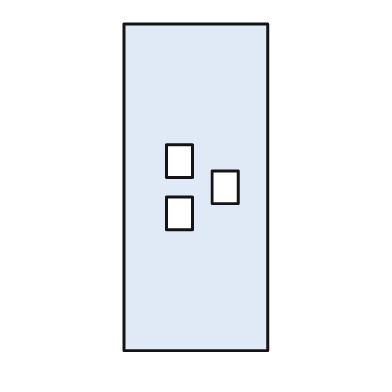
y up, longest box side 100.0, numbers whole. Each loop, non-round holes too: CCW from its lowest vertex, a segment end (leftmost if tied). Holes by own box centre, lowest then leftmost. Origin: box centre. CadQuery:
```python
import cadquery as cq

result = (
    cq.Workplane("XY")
    .moveTo(-22.0, -50.0)
    .lineTo(22.0, -50.0)
    .lineTo(22.0, 50.0)
    .lineTo(-22.0, 50.0)
    .close()
    .moveTo(-9.0, -13.0)
    .lineTo(-1.0, -13.0)
    .lineTo(-1.0, -3.0)
    .lineTo(-9.0, -3.0)
    .close()
    .moveTo(5.0, -5.0)
    .lineTo(13.0, -5.0)
    .lineTo(13.0, 5.0)
    .lineTo(5.0, 5.0)
    .close()
    .moveTo(-9.0, 3.0)
    .lineTo(-1.0, 3.0)
    .lineTo(-1.0, 13.0)
    .lineTo(-9.0, 13.0)
    .close()
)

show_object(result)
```